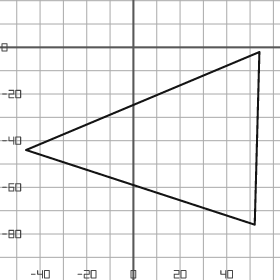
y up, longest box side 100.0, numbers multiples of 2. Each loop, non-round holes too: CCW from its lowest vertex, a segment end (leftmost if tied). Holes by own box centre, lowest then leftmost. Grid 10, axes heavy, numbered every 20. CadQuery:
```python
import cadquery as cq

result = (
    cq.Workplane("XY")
    .moveTo(52.0, -76.0)
    .lineTo(54.0, -2.0)
    .lineTo(-46.0, -44.0)
    .close()
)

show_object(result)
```